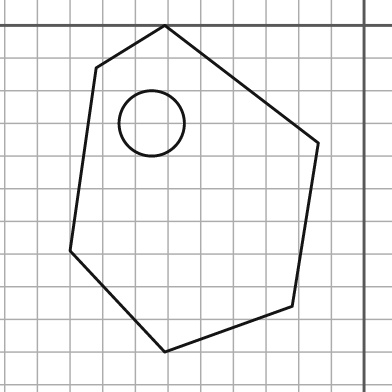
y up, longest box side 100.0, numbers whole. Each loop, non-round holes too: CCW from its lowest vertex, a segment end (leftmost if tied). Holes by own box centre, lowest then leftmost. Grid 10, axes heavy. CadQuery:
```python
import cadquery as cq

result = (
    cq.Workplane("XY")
    .moveTo(-61.0, -100.0)
    .lineTo(-22.0, -86.0)
    .lineTo(-14.0, -36.0)
    .lineTo(-61.0, 0.0)
    .lineTo(-82.0, -13.0)
    .lineTo(-90.0, -69.0)
    .close()
    .moveTo(-65.0, -30.0)
    .circle(10.0)
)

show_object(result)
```